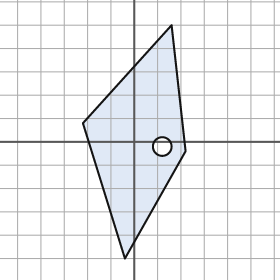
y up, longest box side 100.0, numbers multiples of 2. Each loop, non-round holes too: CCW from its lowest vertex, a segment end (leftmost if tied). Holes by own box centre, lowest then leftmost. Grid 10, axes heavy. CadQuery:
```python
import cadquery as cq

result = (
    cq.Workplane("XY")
    .moveTo(-4.0, -50.0)
    .lineTo(22.0, -4.0)
    .lineTo(16.0, 50.0)
    .lineTo(-22.0, 8.0)
    .close()
    .moveTo(12.0, -2.0)
    .circle(4.0)
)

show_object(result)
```